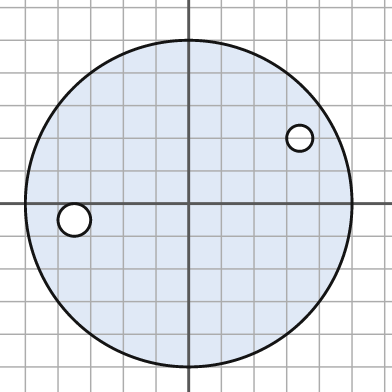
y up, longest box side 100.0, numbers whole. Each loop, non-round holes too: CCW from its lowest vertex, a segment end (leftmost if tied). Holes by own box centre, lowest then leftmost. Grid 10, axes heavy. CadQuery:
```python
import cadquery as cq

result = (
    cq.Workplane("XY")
    .moveTo(0.0, 0.0)
    .circle(50.0)
    .moveTo(-35.0, -5.0)
    .circle(5.0)
    .moveTo(34.0, 20.0)
    .circle(4.0)
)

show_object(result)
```